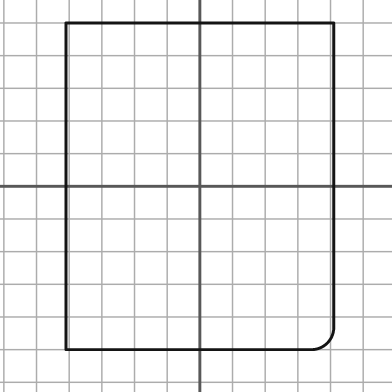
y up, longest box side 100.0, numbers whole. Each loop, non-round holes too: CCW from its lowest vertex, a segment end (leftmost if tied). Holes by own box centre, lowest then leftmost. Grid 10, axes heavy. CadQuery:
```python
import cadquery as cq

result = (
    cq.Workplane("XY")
    .moveTo(-41.0, -50.0)
    .lineTo(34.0, -50.0)
    .threePointArc((39.0, -48.0), (41.0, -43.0))
    .lineTo(41.0, 50.0)
    .lineTo(-41.0, 50.0)
    .close()
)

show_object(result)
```